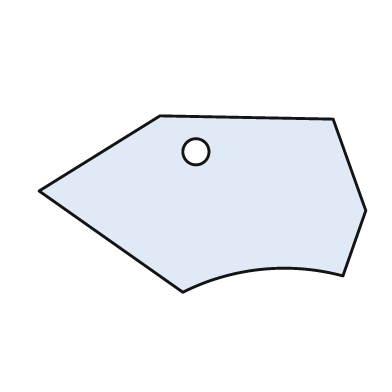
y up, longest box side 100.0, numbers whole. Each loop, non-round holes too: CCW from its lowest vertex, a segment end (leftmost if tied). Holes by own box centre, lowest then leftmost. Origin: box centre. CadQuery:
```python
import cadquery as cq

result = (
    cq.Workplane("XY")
    .moveTo(-6.0, -27.0)
    .threePointArc((18.0, -20.0), (43.0, -22.0))
    .lineTo(50.0, -2.0)
    .lineTo(40.0, 26.0)
    .lineTo(-13.0, 27.0)
    .lineTo(-50.0, 4.0)
    .close()
    .moveTo(-2.0, 16.0)
    .circle(4.0)
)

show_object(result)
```